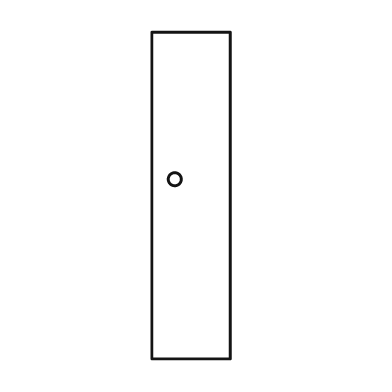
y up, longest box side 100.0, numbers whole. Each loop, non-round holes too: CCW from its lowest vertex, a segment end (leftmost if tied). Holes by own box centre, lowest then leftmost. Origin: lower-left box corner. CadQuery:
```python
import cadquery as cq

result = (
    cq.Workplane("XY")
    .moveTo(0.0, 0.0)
    .lineTo(24.0, 0.0)
    .lineTo(24.0, 100.0)
    .lineTo(0.0, 100.0)
    .close()
    .moveTo(7.0, 55.0)
    .circle(2.0)
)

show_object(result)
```